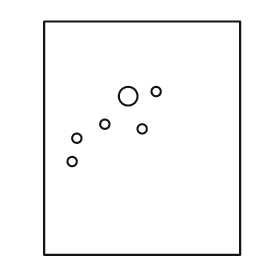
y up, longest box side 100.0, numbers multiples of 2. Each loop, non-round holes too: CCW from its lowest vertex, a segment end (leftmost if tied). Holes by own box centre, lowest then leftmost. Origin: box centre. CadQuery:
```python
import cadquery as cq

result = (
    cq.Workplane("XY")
    .moveTo(-42.0, -50.0)
    .lineTo(42.0, -50.0)
    .lineTo(42.0, 50.0)
    .lineTo(-42.0, 50.0)
    .close()
    .moveTo(-30.0, -10.0)
    .circle(2.0)
    .moveTo(-28.0, 0.0)
    .circle(2.0)
    .moveTo(0.0, 4.0)
    .circle(2.0)
    .moveTo(-16.0, 6.0)
    .circle(2.0)
    .moveTo(-6.0, 18.0)
    .circle(4.0)
    .moveTo(6.0, 20.0)
    .circle(2.0)
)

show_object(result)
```